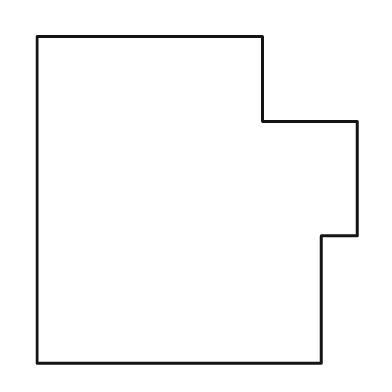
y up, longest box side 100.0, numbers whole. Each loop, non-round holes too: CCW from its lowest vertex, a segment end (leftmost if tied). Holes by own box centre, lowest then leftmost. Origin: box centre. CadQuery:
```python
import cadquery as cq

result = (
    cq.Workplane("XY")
    .moveTo(-49.0, -50.0)
    .lineTo(38.0, -50.0)
    .lineTo(38.0, -11.0)
    .lineTo(49.0, -11.0)
    .lineTo(49.0, 24.0)
    .lineTo(20.0, 24.0)
    .lineTo(20.0, 50.0)
    .lineTo(-49.0, 50.0)
    .close()
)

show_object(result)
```